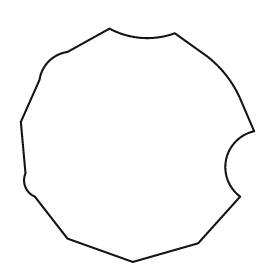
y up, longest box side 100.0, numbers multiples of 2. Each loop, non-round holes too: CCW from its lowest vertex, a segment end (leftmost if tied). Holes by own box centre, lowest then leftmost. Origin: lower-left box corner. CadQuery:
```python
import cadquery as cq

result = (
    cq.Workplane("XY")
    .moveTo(48.0, 0.0)
    .lineTo(76.0, 8.0)
    .lineTo(94.0, 28.0)
    .threePointArc((88.0, 44.0), (100.0, 56.0))
    .lineTo(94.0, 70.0)
    .threePointArc((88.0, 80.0), (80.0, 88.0))
    .lineTo(66.0, 98.0)
    .threePointArc((52.0, 96.0), (38.0, 100.0))
    .lineTo(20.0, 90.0)
    .threePointArc((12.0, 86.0), (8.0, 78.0))
    .lineTo(0.0, 60.0)
    .lineTo(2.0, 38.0)
    .threePointArc((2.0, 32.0), (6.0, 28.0))
    .lineTo(20.0, 10.0)
    .close()
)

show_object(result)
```